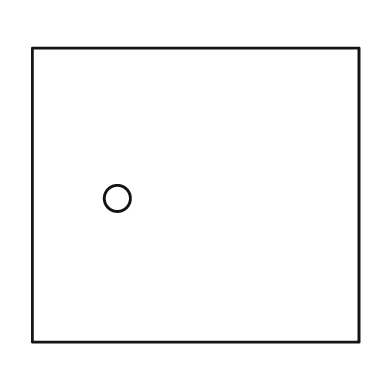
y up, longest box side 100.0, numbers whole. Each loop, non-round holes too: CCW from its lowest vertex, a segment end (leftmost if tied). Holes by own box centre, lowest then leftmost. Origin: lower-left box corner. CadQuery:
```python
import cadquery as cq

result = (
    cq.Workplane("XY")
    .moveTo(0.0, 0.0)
    .lineTo(100.0, 0.0)
    .lineTo(100.0, 90.0)
    .lineTo(0.0, 90.0)
    .close()
    .moveTo(26.0, 44.0)
    .circle(4.0)
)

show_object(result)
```